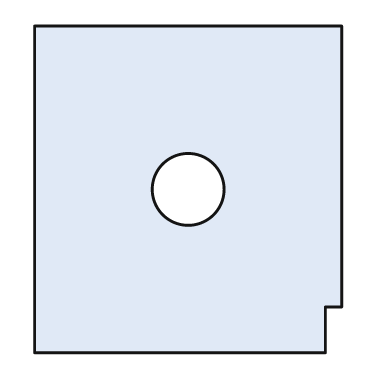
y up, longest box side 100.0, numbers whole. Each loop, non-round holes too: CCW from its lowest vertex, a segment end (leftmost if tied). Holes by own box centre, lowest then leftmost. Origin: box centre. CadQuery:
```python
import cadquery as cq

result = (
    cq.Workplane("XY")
    .moveTo(-47.0, -50.0)
    .lineTo(42.0, -50.0)
    .lineTo(42.0, -36.0)
    .lineTo(47.0, -36.0)
    .lineTo(47.0, 50.0)
    .lineTo(-47.0, 50.0)
    .close()
    .moveTo(0.0, 0.0)
    .circle(11.0)
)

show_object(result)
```